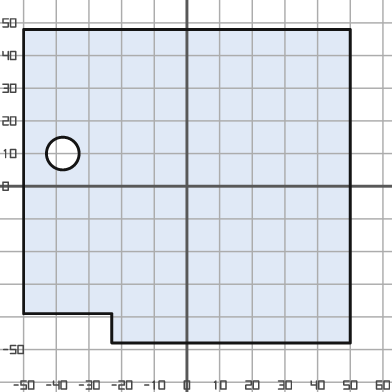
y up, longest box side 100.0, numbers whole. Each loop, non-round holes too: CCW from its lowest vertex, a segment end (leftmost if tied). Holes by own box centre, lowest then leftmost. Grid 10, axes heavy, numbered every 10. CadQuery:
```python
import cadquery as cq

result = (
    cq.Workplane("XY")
    .moveTo(-23.0, -48.0)
    .lineTo(50.0, -48.0)
    .lineTo(50.0, 48.0)
    .lineTo(-50.0, 48.0)
    .lineTo(-50.0, -39.0)
    .lineTo(-23.0, -39.0)
    .close()
    .moveTo(-38.0, 10.0)
    .circle(5.0)
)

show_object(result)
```